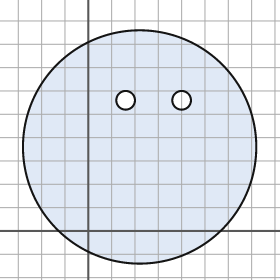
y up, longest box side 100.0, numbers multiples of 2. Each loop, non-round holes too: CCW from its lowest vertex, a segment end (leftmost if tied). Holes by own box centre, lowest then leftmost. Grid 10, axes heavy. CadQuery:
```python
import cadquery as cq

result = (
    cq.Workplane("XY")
    .moveTo(22.0, 36.0)
    .circle(50.0)
    .moveTo(16.0, 56.0)
    .circle(4.0)
    .moveTo(40.0, 56.0)
    .circle(4.0)
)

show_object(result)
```